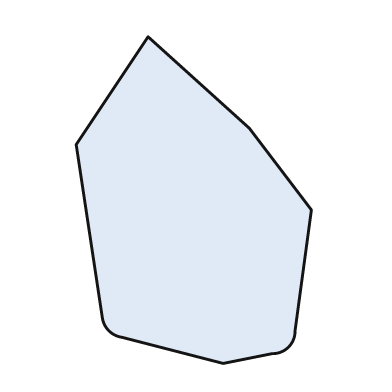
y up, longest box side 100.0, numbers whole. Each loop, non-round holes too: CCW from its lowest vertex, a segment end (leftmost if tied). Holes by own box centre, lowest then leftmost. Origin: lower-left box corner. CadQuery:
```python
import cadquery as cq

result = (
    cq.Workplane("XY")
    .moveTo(45.0, 0.0)
    .lineTo(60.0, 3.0)
    .threePointArc((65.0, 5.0), (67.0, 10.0))
    .lineTo(72.0, 47.0)
    .lineTo(53.0, 72.0)
    .lineTo(22.0, 100.0)
    .lineTo(0.0, 67.0)
    .lineTo(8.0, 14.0)
    .threePointArc((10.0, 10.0), (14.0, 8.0))
    .close()
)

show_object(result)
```